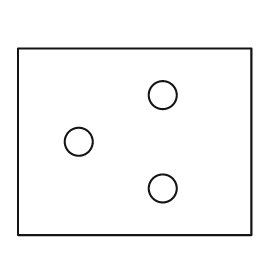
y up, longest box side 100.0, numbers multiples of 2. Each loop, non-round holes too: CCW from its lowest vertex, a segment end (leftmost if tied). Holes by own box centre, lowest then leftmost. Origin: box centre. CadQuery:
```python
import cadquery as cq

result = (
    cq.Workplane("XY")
    .moveTo(-50.0, -40.0)
    .lineTo(50.0, -40.0)
    .lineTo(50.0, 40.0)
    .lineTo(-50.0, 40.0)
    .close()
    .moveTo(12.0, -20.0)
    .circle(6.0)
    .moveTo(-24.0, 0.0)
    .circle(6.0)
    .moveTo(12.0, 20.0)
    .circle(6.0)
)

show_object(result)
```